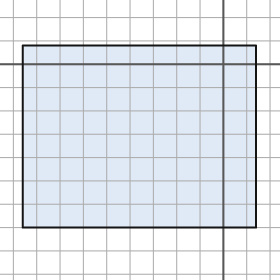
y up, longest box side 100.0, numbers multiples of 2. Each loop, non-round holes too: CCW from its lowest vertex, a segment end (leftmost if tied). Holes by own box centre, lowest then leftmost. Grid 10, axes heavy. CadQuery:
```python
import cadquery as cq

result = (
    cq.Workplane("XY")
    .moveTo(-86.0, -70.0)
    .lineTo(14.0, -70.0)
    .lineTo(14.0, 8.0)
    .lineTo(-86.0, 8.0)
    .close()
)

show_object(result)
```